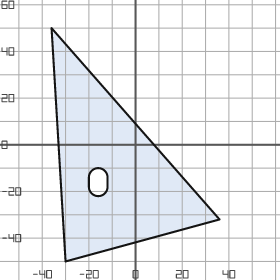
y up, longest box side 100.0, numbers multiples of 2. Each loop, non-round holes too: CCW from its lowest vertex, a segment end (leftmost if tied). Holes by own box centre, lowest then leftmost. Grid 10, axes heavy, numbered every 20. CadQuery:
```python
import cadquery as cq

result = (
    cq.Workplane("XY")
    .moveTo(-30.0, -50.0)
    .lineTo(36.0, -32.0)
    .lineTo(-36.0, 50.0)
    .close()
    .moveTo(-20.0, -18.0)
    .threePointArc((-16.0, -22.0), (-12.0, -18.0))
    .lineTo(-12.0, -14.0)
    .threePointArc((-16.0, -10.0), (-20.0, -14.0))
    .close()
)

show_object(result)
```